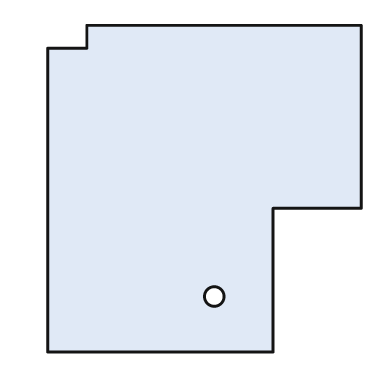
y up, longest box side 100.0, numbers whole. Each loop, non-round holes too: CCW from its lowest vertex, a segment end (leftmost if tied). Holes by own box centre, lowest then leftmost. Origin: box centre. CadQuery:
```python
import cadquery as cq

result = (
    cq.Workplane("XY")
    .moveTo(-48.0, -50.0)
    .lineTo(21.0, -50.0)
    .lineTo(21.0, -6.0)
    .lineTo(48.0, -6.0)
    .lineTo(48.0, 50.0)
    .lineTo(-36.0, 50.0)
    .lineTo(-36.0, 43.0)
    .lineTo(-48.0, 43.0)
    .close()
    .moveTo(3.0, -33.0)
    .circle(3.0)
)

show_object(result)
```